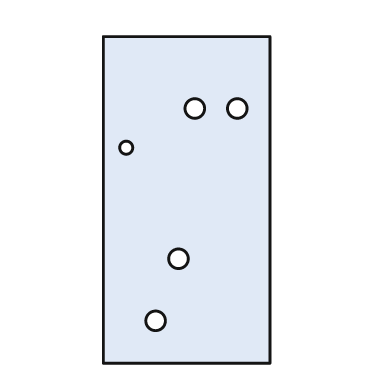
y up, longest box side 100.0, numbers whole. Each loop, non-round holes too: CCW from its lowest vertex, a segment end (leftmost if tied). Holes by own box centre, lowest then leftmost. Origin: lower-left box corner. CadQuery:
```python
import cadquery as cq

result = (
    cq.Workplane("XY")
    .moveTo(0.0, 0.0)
    .lineTo(51.0, 0.0)
    .lineTo(51.0, 100.0)
    .lineTo(0.0, 100.0)
    .close()
    .moveTo(16.0, 13.0)
    .circle(3.0)
    .moveTo(23.0, 32.0)
    .circle(3.0)
    .moveTo(7.0, 66.0)
    .circle(2.0)
    .moveTo(28.0, 78.0)
    .circle(3.0)
    .moveTo(41.0, 78.0)
    .circle(3.0)
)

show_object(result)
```